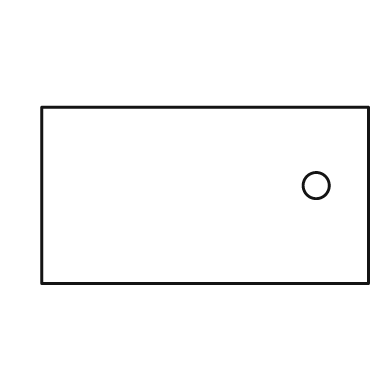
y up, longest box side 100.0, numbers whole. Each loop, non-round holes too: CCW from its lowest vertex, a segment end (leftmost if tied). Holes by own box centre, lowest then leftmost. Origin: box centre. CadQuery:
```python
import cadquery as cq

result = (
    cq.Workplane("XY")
    .moveTo(-50.0, -27.0)
    .lineTo(50.0, -27.0)
    .lineTo(50.0, 27.0)
    .lineTo(-50.0, 27.0)
    .close()
    .moveTo(34.0, 3.0)
    .circle(4.0)
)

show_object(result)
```